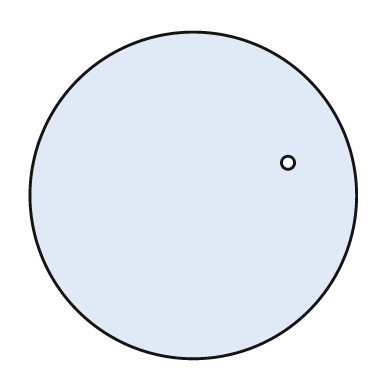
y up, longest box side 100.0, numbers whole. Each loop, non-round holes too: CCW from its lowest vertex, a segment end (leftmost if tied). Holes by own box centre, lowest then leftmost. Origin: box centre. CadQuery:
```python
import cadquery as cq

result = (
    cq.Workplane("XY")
    .moveTo(0.0, 0.0)
    .circle(50.0)
    .moveTo(29.0, 10.0)
    .circle(2.0)
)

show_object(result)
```